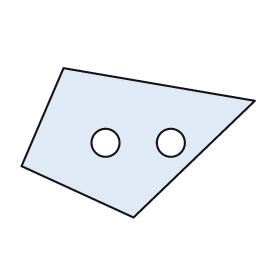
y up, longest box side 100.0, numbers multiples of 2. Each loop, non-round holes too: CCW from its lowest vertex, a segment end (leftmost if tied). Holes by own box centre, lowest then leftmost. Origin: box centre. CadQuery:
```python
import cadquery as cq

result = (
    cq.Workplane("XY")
    .moveTo(-2.0, -32.0)
    .lineTo(50.0, 18.0)
    .lineTo(-32.0, 32.0)
    .lineTo(-50.0, -10.0)
    .close()
    .moveTo(-14.0, 0.0)
    .circle(6.0)
    .moveTo(14.0, 0.0)
    .circle(6.0)
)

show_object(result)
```